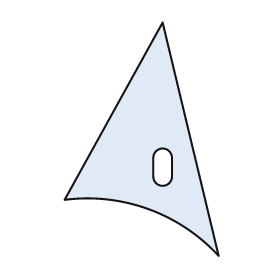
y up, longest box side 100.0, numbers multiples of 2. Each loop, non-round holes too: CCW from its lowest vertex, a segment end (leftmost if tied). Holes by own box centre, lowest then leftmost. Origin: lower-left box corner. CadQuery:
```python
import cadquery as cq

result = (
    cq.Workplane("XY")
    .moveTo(66.0, 0.0)
    .lineTo(42.0, 100.0)
    .lineTo(0.0, 24.0)
    .threePointArc((36.0, 20.0), (66.0, 0.0))
    .close()
    .moveTo(38.0, 34.0)
    .threePointArc((42.0, 30.0), (46.0, 34.0))
    .lineTo(46.0, 42.0)
    .threePointArc((42.0, 46.0), (38.0, 42.0))
    .close()
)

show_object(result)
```